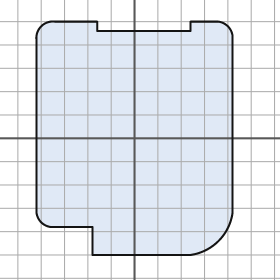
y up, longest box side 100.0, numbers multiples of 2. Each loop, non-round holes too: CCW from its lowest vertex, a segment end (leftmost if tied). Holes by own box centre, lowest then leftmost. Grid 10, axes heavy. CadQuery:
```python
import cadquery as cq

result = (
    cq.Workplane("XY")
    .moveTo(-18.0, -50.0)
    .lineTo(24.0, -50.0)
    .threePointArc((36.0, -44.0), (42.0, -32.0))
    .lineTo(42.0, 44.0)
    .threePointArc((40.0, 48.0), (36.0, 50.0))
    .lineTo(24.0, 50.0)
    .lineTo(24.0, 46.0)
    .lineTo(-16.0, 46.0)
    .lineTo(-16.0, 50.0)
    .lineTo(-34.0, 50.0)
    .threePointArc((-40.0, 48.0), (-42.0, 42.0))
    .lineTo(-42.0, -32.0)
    .threePointArc((-40.0, -36.0), (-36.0, -38.0))
    .lineTo(-18.0, -38.0)
    .close()
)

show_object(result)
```